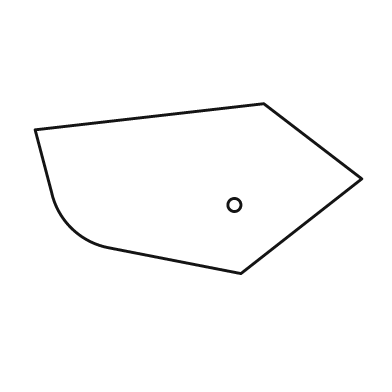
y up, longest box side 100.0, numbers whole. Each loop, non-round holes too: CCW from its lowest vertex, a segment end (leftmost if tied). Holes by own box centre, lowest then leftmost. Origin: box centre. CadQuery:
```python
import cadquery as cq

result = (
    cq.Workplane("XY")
    .moveTo(13.0, -26.0)
    .lineTo(50.0, 3.0)
    .lineTo(20.0, 26.0)
    .lineTo(-50.0, 18.0)
    .lineTo(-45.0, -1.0)
    .threePointArc((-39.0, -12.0), (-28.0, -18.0))
    .close()
    .moveTo(11.0, -5.0)
    .circle(2.0)
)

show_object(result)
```